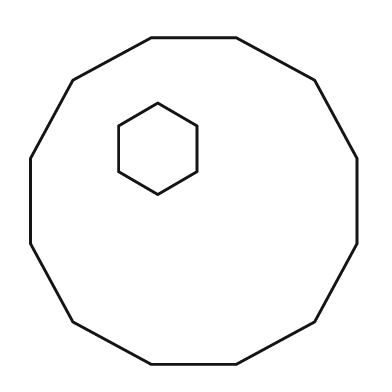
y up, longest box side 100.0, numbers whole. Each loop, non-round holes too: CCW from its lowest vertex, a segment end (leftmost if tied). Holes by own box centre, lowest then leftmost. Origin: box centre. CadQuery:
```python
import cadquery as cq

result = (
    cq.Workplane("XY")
    .moveTo(-13.0, -50.0)
    .lineTo(13.0, -50.0)
    .lineTo(37.0, -37.0)
    .lineTo(50.0, -13.0)
    .lineTo(50.0, 13.0)
    .lineTo(37.0, 37.0)
    .lineTo(13.0, 50.0)
    .lineTo(-13.0, 50.0)
    .lineTo(-37.0, 37.0)
    .lineTo(-50.0, 13.0)
    .lineTo(-50.0, -13.0)
    .lineTo(-37.0, -37.0)
    .close()
    .moveTo(-11.0, 2.0)
    .lineTo(1.0, 9.0)
    .lineTo(1.0, 23.0)
    .lineTo(-11.0, 30.0)
    .lineTo(-23.0, 23.0)
    .lineTo(-23.0, 9.0)
    .close()
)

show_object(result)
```